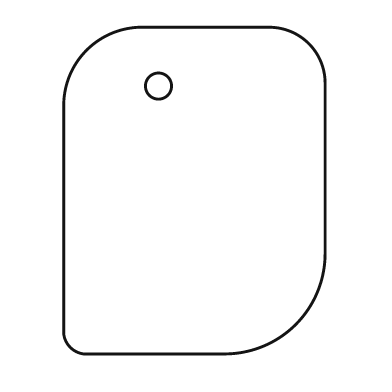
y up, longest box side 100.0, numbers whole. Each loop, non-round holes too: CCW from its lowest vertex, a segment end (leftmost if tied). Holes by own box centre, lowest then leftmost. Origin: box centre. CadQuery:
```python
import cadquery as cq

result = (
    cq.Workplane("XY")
    .moveTo(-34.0, -50.0)
    .lineTo(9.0, -50.0)
    .threePointArc((31.0, -41.0), (40.0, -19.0))
    .lineTo(40.0, 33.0)
    .threePointArc((35.0, 45.0), (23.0, 50.0))
    .lineTo(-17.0, 50.0)
    .threePointArc((-33.0, 43.0), (-40.0, 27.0))
    .lineTo(-40.0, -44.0)
    .threePointArc((-38.0, -48.0), (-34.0, -50.0))
    .close()
    .moveTo(-11.0, 32.0)
    .circle(4.0)
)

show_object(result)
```